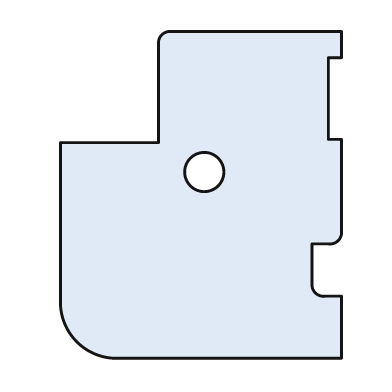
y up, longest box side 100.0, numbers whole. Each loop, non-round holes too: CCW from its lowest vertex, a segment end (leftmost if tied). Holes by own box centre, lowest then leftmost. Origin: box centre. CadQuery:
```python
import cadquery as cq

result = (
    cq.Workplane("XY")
    .moveTo(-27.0, -50.0)
    .lineTo(43.0, -50.0)
    .lineTo(43.0, -31.0)
    .lineTo(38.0, -31.0)
    .threePointArc((35.0, -30.0), (34.0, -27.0))
    .lineTo(34.0, -15.0)
    .lineTo(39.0, -15.0)
    .threePointArc((42.0, -14.0), (43.0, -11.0))
    .lineTo(43.0, 17.0)
    .lineTo(39.0, 17.0)
    .lineTo(39.0, 42.0)
    .lineTo(43.0, 42.0)
    .lineTo(43.0, 50.0)
    .lineTo(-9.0, 50.0)
    .threePointArc((-12.0, 49.0), (-13.0, 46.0))
    .lineTo(-13.0, 16.0)
    .lineTo(-43.0, 16.0)
    .lineTo(-43.0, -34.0)
    .threePointArc((-38.0, -45.0), (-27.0, -50.0))
    .close()
    .moveTo(1.0, 7.0)
    .circle(6.0)
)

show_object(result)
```